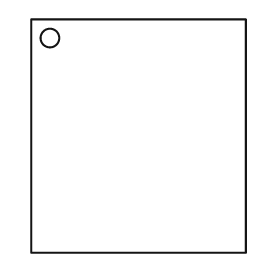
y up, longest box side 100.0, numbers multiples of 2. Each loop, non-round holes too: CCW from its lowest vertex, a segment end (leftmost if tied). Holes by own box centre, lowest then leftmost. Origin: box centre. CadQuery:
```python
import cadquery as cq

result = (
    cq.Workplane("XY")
    .moveTo(-46.0, -50.0)
    .lineTo(46.0, -50.0)
    .lineTo(46.0, 50.0)
    .lineTo(-46.0, 50.0)
    .close()
    .moveTo(-38.0, 42.0)
    .circle(4.0)
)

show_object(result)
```